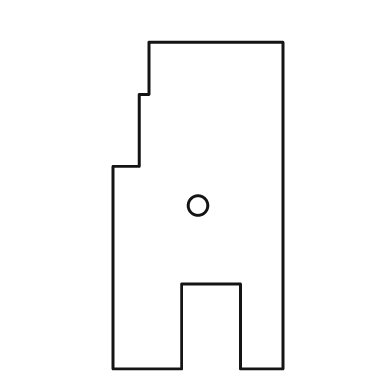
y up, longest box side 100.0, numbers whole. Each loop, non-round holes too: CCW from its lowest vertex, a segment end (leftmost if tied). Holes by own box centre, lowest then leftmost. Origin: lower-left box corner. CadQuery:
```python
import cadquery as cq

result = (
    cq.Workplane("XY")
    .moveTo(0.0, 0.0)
    .lineTo(21.0, 0.0)
    .lineTo(21.0, 26.0)
    .lineTo(39.0, 26.0)
    .lineTo(39.0, 0.0)
    .lineTo(52.0, 0.0)
    .lineTo(52.0, 100.0)
    .lineTo(11.0, 100.0)
    .lineTo(11.0, 84.0)
    .lineTo(8.0, 84.0)
    .lineTo(8.0, 62.0)
    .lineTo(0.0, 62.0)
    .close()
    .moveTo(26.0, 50.0)
    .circle(3.0)
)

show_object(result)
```